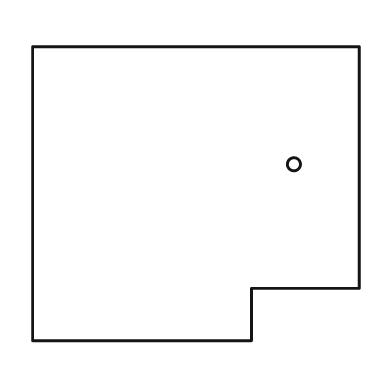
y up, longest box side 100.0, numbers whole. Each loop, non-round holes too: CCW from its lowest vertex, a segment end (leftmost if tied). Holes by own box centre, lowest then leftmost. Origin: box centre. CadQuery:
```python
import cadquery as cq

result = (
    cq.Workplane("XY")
    .moveTo(-50.0, -45.0)
    .lineTo(17.0, -45.0)
    .lineTo(17.0, -29.0)
    .lineTo(50.0, -29.0)
    .lineTo(50.0, 45.0)
    .lineTo(-50.0, 45.0)
    .close()
    .moveTo(30.0, 9.0)
    .circle(2.0)
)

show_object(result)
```